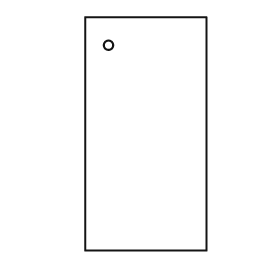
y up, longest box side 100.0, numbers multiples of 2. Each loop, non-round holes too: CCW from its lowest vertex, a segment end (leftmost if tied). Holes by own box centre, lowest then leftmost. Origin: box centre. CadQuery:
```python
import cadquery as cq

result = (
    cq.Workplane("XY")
    .moveTo(-26.0, -50.0)
    .lineTo(26.0, -50.0)
    .lineTo(26.0, 50.0)
    .lineTo(-26.0, 50.0)
    .close()
    .moveTo(-16.0, 38.0)
    .circle(2.0)
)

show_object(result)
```